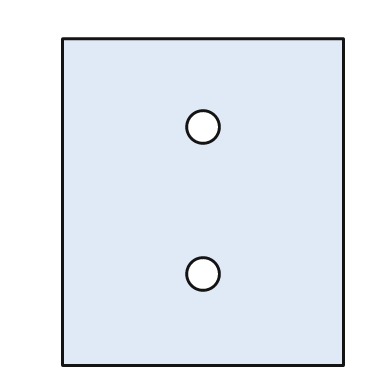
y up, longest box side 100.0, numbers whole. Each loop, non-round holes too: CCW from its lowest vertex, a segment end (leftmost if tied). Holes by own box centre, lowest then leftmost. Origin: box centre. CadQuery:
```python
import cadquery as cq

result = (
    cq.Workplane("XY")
    .moveTo(-43.0, -50.0)
    .lineTo(43.0, -50.0)
    .lineTo(43.0, 50.0)
    .lineTo(-43.0, 50.0)
    .close()
    .moveTo(0.0, -22.0)
    .circle(5.0)
    .moveTo(0.0, 23.0)
    .circle(5.0)
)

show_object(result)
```